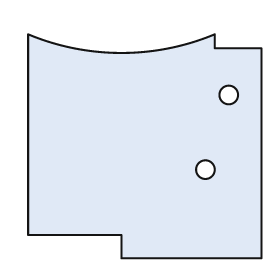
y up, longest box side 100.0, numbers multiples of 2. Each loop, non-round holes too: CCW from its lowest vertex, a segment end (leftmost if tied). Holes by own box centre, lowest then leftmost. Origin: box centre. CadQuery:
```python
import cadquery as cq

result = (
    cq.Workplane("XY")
    .moveTo(-10.0, -48.0)
    .lineTo(50.0, -48.0)
    .lineTo(50.0, 42.0)
    .lineTo(30.0, 42.0)
    .lineTo(30.0, 48.0)
    .threePointArc((-10.0, 40.0), (-50.0, 48.0))
    .lineTo(-50.0, -38.0)
    .lineTo(-10.0, -38.0)
    .close()
    .moveTo(26.0, -10.0)
    .circle(4.0)
    .moveTo(36.0, 22.0)
    .circle(4.0)
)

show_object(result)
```